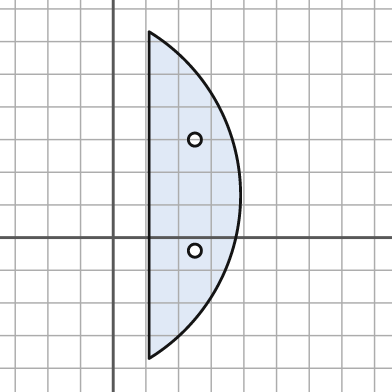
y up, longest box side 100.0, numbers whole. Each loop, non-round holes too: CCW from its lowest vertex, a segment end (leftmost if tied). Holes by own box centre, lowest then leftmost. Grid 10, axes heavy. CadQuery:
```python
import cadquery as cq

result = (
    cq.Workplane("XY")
    .moveTo(11.0, -37.0)
    .threePointArc((39.0, 13.0), (11.0, 63.0))
    .close()
    .moveTo(25.0, -4.0)
    .circle(2.0)
    .moveTo(25.0, 30.0)
    .circle(2.0)
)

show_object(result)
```